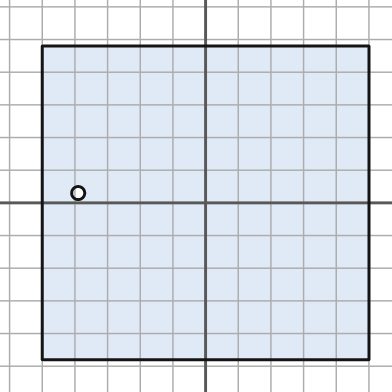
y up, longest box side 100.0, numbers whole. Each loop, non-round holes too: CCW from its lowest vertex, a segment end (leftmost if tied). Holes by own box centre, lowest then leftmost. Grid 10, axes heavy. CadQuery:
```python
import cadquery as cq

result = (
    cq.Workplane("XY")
    .moveTo(-50.0, -48.0)
    .lineTo(50.0, -48.0)
    .lineTo(50.0, 48.0)
    .lineTo(-50.0, 48.0)
    .close()
    .moveTo(-39.0, 3.0)
    .circle(2.0)
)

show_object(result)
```